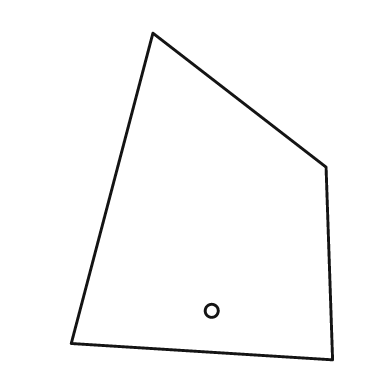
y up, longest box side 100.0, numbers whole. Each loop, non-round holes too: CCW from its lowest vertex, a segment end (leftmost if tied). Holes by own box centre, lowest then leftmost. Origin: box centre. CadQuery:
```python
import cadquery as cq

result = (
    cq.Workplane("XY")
    .moveTo(40.0, -50.0)
    .lineTo(38.0, 9.0)
    .lineTo(-15.0, 50.0)
    .lineTo(-40.0, -45.0)
    .close()
    .moveTo(3.0, -35.0)
    .circle(2.0)
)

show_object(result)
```